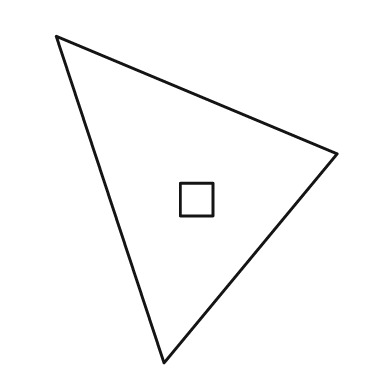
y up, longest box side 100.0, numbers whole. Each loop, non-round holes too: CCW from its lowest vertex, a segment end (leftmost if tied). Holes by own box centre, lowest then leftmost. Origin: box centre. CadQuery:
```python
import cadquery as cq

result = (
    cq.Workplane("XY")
    .moveTo(-10.0, -50.0)
    .lineTo(43.0, 14.0)
    .lineTo(-43.0, 50.0)
    .close()
    .moveTo(-5.0, -5.0)
    .lineTo(5.0, -5.0)
    .lineTo(5.0, 5.0)
    .lineTo(-5.0, 5.0)
    .close()
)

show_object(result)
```